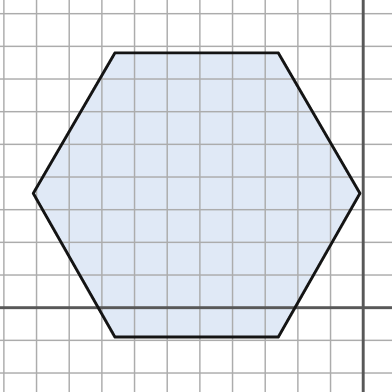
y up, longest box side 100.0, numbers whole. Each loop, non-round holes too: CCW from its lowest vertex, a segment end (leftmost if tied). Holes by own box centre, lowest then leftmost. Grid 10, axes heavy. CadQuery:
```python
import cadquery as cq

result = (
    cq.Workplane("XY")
    .moveTo(-76.0, -9.0)
    .lineTo(-26.0, -9.0)
    .lineTo(-1.0, 35.0)
    .lineTo(-26.0, 78.0)
    .lineTo(-76.0, 78.0)
    .lineTo(-101.0, 35.0)
    .close()
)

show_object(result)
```